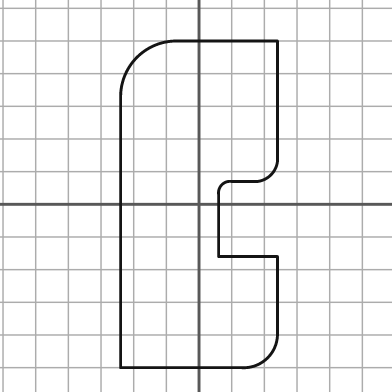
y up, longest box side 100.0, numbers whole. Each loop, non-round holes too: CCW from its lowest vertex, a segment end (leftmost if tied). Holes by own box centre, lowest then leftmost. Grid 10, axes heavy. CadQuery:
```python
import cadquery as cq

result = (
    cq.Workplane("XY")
    .moveTo(-24.0, -50.0)
    .lineTo(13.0, -50.0)
    .threePointArc((21.0, -47.0), (24.0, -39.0))
    .lineTo(24.0, -16.0)
    .lineTo(6.0, -16.0)
    .lineTo(6.0, 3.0)
    .threePointArc((7.0, 6.0), (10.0, 7.0))
    .lineTo(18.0, 7.0)
    .threePointArc((22.0, 9.0), (24.0, 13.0))
    .lineTo(24.0, 50.0)
    .lineTo(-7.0, 50.0)
    .threePointArc((-19.0, 45.0), (-24.0, 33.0))
    .close()
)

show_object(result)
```